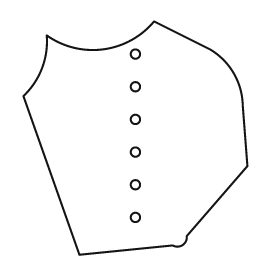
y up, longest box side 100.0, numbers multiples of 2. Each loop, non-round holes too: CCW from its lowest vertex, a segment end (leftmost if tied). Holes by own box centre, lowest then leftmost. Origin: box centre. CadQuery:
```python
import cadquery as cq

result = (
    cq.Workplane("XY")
    .moveTo(-24.0, -50.0)
    .lineTo(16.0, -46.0)
    .threePointArc((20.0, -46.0), (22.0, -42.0))
    .lineTo(48.0, -12.0)
    .lineTo(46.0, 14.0)
    .threePointArc((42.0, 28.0), (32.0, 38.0))
    .lineTo(8.0, 50.0)
    .threePointArc((-14.0, 38.0), (-38.0, 44.0))
    .threePointArc((-40.0, 30.0), (-48.0, 18.0))
    .close()
    .moveTo(0.0, -34.0)
    .circle(2.0)
    .moveTo(0.0, -20.0)
    .circle(2.0)
    .moveTo(0.0, -6.0)
    .circle(2.0)
    .moveTo(0.0, 8.0)
    .circle(2.0)
    .moveTo(0.0, 22.0)
    .circle(2.0)
    .moveTo(0.0, 36.0)
    .circle(2.0)
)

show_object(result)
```